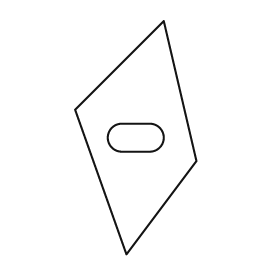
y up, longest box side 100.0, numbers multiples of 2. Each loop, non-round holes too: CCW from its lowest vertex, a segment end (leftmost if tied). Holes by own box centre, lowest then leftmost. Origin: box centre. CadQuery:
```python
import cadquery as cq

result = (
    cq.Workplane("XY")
    .moveTo(-4.0, -50.0)
    .lineTo(26.0, -10.0)
    .lineTo(12.0, 50.0)
    .lineTo(-26.0, 12.0)
    .close()
    .moveTo(-6.0, -6.0)
    .lineTo(6.0, -6.0)
    .threePointArc((12.0, 0.0), (6.0, 6.0))
    .lineTo(-6.0, 6.0)
    .threePointArc((-12.0, 0.0), (-6.0, -6.0))
    .close()
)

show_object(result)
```